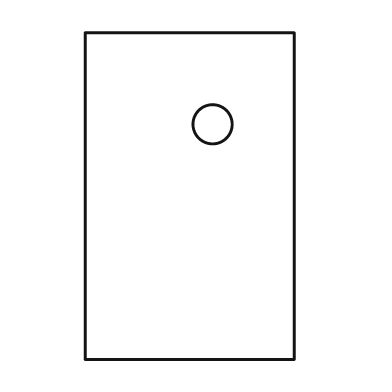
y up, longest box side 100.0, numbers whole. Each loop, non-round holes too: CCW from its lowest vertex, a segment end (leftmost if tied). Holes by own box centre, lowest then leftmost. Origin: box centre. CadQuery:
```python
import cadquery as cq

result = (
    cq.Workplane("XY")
    .moveTo(-32.0, -50.0)
    .lineTo(32.0, -50.0)
    .lineTo(32.0, 50.0)
    .lineTo(-32.0, 50.0)
    .close()
    .moveTo(7.0, 22.0)
    .circle(6.0)
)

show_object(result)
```